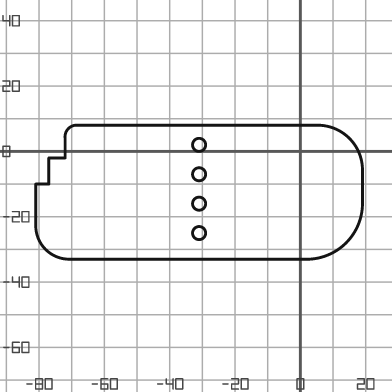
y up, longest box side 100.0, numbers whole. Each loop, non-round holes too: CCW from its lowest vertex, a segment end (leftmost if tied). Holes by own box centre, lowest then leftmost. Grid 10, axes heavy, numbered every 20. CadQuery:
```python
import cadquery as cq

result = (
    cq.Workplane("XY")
    .moveTo(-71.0, -33.0)
    .lineTo(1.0, -33.0)
    .threePointArc((14.0, -28.0), (19.0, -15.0))
    .lineTo(19.0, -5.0)
    .threePointArc((15.0, 4.0), (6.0, 8.0))
    .lineTo(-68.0, 8.0)
    .threePointArc((-71.0, 7.0), (-72.0, 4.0))
    .lineTo(-72.0, -2.0)
    .lineTo(-77.0, -2.0)
    .lineTo(-77.0, -10.0)
    .lineTo(-81.0, -10.0)
    .lineTo(-81.0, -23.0)
    .threePointArc((-78.0, -30.0), (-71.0, -33.0))
    .close()
    .moveTo(-31.0, -25.0)
    .circle(2.0)
    .moveTo(-31.0, -16.0)
    .circle(2.0)
    .moveTo(-31.0, -7.0)
    .circle(2.0)
    .moveTo(-31.0, 2.0)
    .circle(2.0)
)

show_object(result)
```